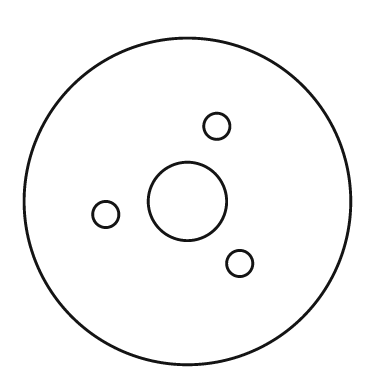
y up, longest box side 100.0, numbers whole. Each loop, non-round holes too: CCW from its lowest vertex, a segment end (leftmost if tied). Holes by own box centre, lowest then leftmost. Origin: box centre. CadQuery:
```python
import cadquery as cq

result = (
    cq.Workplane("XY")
    .moveTo(0.0, 0.0)
    .circle(50.0)
    .moveTo(16.0, -19.0)
    .circle(4.0)
    .moveTo(-25.0, -4.0)
    .circle(4.0)
    .moveTo(0.0, 0.0)
    .circle(12.0)
    .moveTo(9.0, 23.0)
    .circle(4.0)
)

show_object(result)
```